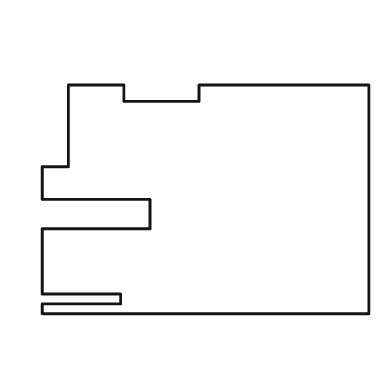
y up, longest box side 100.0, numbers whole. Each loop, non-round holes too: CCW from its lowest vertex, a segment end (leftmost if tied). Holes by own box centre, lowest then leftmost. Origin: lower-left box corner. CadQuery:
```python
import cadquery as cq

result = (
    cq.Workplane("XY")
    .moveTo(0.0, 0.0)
    .lineTo(100.0, 0.0)
    .lineTo(100.0, 70.0)
    .lineTo(48.0, 70.0)
    .lineTo(48.0, 65.0)
    .lineTo(25.0, 65.0)
    .lineTo(25.0, 70.0)
    .lineTo(8.0, 70.0)
    .lineTo(8.0, 45.0)
    .lineTo(0.0, 45.0)
    .lineTo(0.0, 35.0)
    .lineTo(33.0, 35.0)
    .lineTo(33.0, 26.0)
    .lineTo(0.0, 26.0)
    .lineTo(0.0, 6.0)
    .lineTo(24.0, 6.0)
    .lineTo(24.0, 3.0)
    .lineTo(0.0, 3.0)
    .close()
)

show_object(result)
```